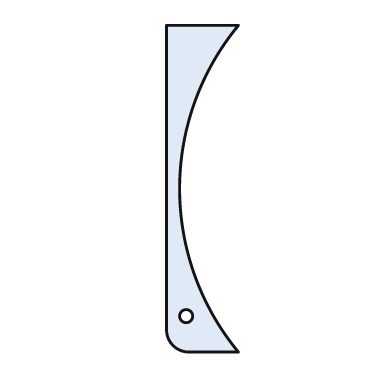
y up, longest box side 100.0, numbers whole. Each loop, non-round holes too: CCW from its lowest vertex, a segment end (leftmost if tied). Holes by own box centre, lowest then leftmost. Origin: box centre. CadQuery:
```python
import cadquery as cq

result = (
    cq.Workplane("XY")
    .moveTo(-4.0, -50.0)
    .lineTo(11.0, -50.0)
    .threePointArc((-7.0, 0.0), (11.0, 50.0))
    .lineTo(-11.0, 50.0)
    .lineTo(-11.0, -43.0)
    .threePointArc((-9.0, -48.0), (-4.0, -50.0))
    .close()
    .moveTo(-5.0, -39.0)
    .circle(2.0)
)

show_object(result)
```